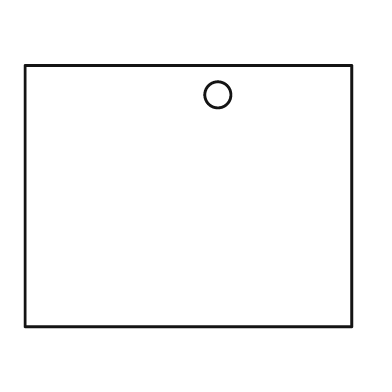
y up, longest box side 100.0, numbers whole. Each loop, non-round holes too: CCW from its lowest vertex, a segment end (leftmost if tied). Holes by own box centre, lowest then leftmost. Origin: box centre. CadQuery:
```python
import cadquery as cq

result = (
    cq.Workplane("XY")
    .moveTo(-50.0, -40.0)
    .lineTo(50.0, -40.0)
    .lineTo(50.0, 40.0)
    .lineTo(-50.0, 40.0)
    .close()
    .moveTo(9.0, 31.0)
    .circle(4.0)
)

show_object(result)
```